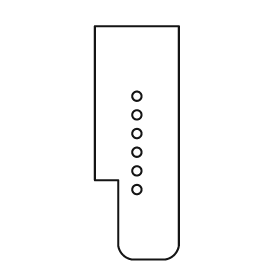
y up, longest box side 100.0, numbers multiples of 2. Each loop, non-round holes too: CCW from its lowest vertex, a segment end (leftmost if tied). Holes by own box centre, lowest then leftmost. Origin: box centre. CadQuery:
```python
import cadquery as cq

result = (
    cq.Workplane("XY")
    .moveTo(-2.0, -50.0)
    .lineTo(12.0, -50.0)
    .threePointArc((16.0, -48.0), (18.0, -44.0))
    .lineTo(18.0, 50.0)
    .lineTo(-18.0, 50.0)
    .lineTo(-18.0, -16.0)
    .lineTo(-8.0, -16.0)
    .lineTo(-8.0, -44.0)
    .threePointArc((-6.0, -48.0), (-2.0, -50.0))
    .close()
    .moveTo(0.0, -20.0)
    .circle(2.0)
    .moveTo(0.0, -12.0)
    .circle(2.0)
    .moveTo(0.0, -4.0)
    .circle(2.0)
    .moveTo(0.0, 4.0)
    .circle(2.0)
    .moveTo(0.0, 12.0)
    .circle(2.0)
    .moveTo(0.0, 20.0)
    .circle(2.0)
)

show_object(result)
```